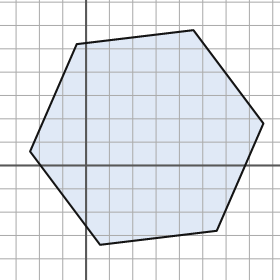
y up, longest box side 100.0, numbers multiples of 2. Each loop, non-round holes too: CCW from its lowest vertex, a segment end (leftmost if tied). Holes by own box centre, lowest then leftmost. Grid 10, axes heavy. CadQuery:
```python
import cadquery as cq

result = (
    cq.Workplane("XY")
    .moveTo(6.0, -34.0)
    .lineTo(56.0, -28.0)
    .lineTo(76.0, 18.0)
    .lineTo(46.0, 58.0)
    .lineTo(-4.0, 52.0)
    .lineTo(-24.0, 6.0)
    .close()
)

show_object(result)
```